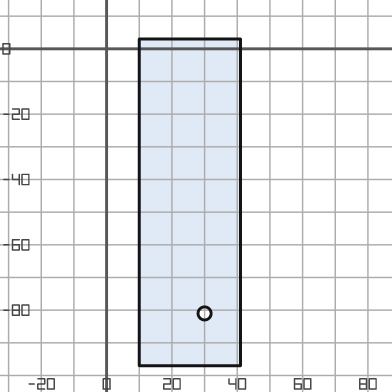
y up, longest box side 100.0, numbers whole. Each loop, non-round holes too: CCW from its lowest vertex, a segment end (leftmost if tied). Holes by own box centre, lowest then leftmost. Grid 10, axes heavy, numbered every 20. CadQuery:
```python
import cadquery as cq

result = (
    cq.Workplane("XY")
    .moveTo(10.0, -97.0)
    .lineTo(41.0, -97.0)
    .lineTo(41.0, 3.0)
    .lineTo(10.0, 3.0)
    .close()
    .moveTo(30.0, -81.0)
    .circle(2.0)
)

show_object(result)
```